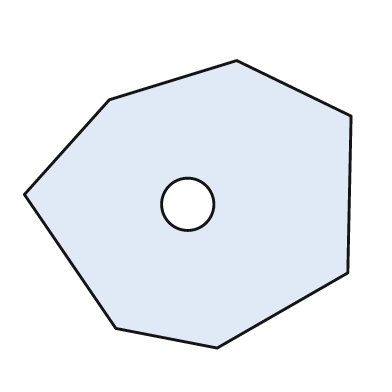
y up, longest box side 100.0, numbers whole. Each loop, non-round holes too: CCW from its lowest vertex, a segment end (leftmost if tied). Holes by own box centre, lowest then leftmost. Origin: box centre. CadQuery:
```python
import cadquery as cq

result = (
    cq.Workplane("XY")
    .moveTo(9.0, -44.0)
    .lineTo(49.0, -21.0)
    .lineTo(50.0, 27.0)
    .lineTo(15.0, 44.0)
    .lineTo(-24.0, 32.0)
    .lineTo(-50.0, 3.0)
    .lineTo(-22.0, -38.0)
    .close()
    .moveTo(0.0, 0.0)
    .circle(8.0)
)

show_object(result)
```